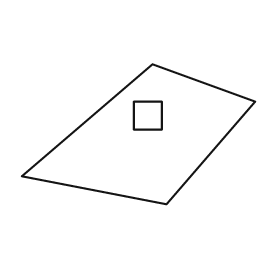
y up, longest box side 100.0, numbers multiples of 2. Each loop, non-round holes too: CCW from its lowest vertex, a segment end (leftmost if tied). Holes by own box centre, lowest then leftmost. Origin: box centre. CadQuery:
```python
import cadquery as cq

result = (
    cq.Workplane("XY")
    .moveTo(12.0, -30.0)
    .lineTo(50.0, 14.0)
    .lineTo(6.0, 30.0)
    .lineTo(-50.0, -18.0)
    .close()
    .moveTo(-2.0, 2.0)
    .lineTo(10.0, 2.0)
    .lineTo(10.0, 14.0)
    .lineTo(-2.0, 14.0)
    .close()
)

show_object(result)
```